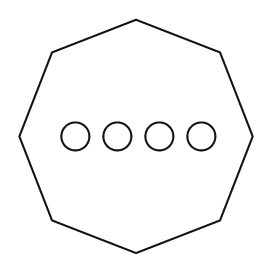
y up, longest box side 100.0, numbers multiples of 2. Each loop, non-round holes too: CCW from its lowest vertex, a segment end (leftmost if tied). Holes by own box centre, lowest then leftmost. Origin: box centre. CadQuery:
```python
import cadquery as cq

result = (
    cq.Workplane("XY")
    .moveTo(0.0, -50.0)
    .lineTo(36.0, -36.0)
    .lineTo(50.0, 0.0)
    .lineTo(36.0, 36.0)
    .lineTo(0.0, 50.0)
    .lineTo(-36.0, 36.0)
    .lineTo(-50.0, 0.0)
    .lineTo(-36.0, -36.0)
    .close()
    .moveTo(-26.0, 0.0)
    .circle(6.0)
    .moveTo(-8.0, 0.0)
    .circle(6.0)
    .moveTo(10.0, 0.0)
    .circle(6.0)
    .moveTo(28.0, 0.0)
    .circle(6.0)
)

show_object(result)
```